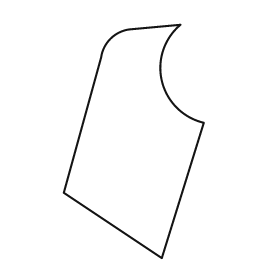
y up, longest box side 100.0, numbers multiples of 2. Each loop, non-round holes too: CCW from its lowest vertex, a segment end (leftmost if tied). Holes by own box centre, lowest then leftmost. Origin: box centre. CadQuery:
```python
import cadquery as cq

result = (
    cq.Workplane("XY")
    .moveTo(12.0, -50.0)
    .lineTo(30.0, 8.0)
    .threePointArc((12.0, 26.0), (20.0, 50.0))
    .lineTo(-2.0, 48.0)
    .threePointArc((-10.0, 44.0), (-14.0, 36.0))
    .lineTo(-30.0, -22.0)
    .close()
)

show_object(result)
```